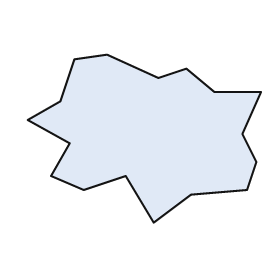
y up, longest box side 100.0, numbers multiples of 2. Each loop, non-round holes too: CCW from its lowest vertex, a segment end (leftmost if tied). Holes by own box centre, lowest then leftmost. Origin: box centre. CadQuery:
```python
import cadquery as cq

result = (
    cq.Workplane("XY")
    .moveTo(4.0, -36.0)
    .lineTo(20.0, -24.0)
    .lineTo(44.0, -22.0)
    .lineTo(48.0, -10.0)
    .lineTo(42.0, 2.0)
    .lineTo(50.0, 20.0)
    .lineTo(30.0, 20.0)
    .lineTo(18.0, 30.0)
    .lineTo(6.0, 26.0)
    .lineTo(-16.0, 36.0)
    .lineTo(-30.0, 34.0)
    .lineTo(-36.0, 16.0)
    .lineTo(-50.0, 8.0)
    .lineTo(-32.0, -2.0)
    .lineTo(-40.0, -16.0)
    .lineTo(-26.0, -22.0)
    .lineTo(-8.0, -16.0)
    .close()
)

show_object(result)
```